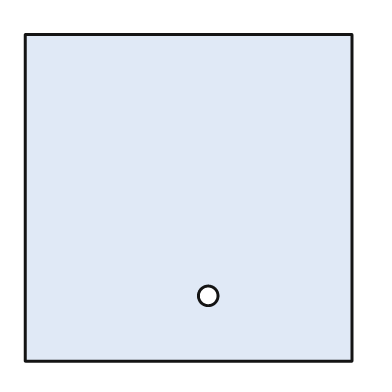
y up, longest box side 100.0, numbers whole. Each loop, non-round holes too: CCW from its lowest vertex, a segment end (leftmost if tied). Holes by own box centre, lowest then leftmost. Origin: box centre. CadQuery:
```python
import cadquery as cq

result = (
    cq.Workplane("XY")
    .moveTo(-50.0, -50.0)
    .lineTo(50.0, -50.0)
    .lineTo(50.0, 50.0)
    .lineTo(-50.0, 50.0)
    .close()
    .moveTo(6.0, -30.0)
    .circle(3.0)
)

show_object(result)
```